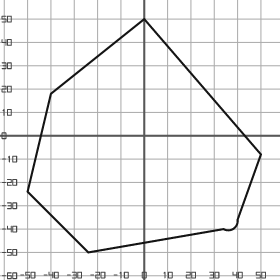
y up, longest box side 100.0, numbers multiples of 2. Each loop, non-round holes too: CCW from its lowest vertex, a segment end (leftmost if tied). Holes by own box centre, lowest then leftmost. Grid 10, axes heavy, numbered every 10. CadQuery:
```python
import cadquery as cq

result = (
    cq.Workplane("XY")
    .moveTo(-24.0, -50.0)
    .lineTo(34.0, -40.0)
    .threePointArc((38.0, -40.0), (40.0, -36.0))
    .lineTo(50.0, -8.0)
    .lineTo(0.0, 50.0)
    .lineTo(-40.0, 18.0)
    .lineTo(-50.0, -24.0)
    .close()
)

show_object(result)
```